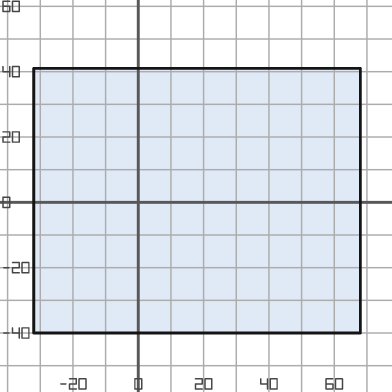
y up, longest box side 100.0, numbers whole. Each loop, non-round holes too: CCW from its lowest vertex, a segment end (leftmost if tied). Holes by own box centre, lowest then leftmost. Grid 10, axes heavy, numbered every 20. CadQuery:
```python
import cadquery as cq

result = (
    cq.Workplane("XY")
    .moveTo(-32.0, -40.0)
    .lineTo(68.0, -40.0)
    .lineTo(68.0, 41.0)
    .lineTo(-32.0, 41.0)
    .close()
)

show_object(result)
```